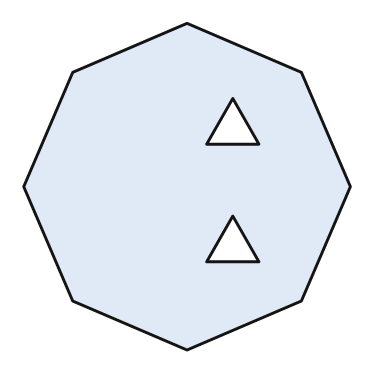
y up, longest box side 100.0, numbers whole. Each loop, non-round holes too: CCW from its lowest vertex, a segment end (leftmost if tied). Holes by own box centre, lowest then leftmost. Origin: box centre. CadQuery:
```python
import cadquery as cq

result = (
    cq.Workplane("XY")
    .moveTo(0.0, -50.0)
    .lineTo(35.0, -35.0)
    .lineTo(50.0, 0.0)
    .lineTo(35.0, 35.0)
    .lineTo(0.0, 50.0)
    .lineTo(-35.0, 35.0)
    .lineTo(-50.0, 0.0)
    .lineTo(-35.0, -35.0)
    .close()
    .moveTo(6.0, -23.0)
    .lineTo(22.0, -23.0)
    .lineTo(14.0, -9.0)
    .close()
    .moveTo(6.0, 13.0)
    .lineTo(22.0, 13.0)
    .lineTo(14.0, 27.0)
    .close()
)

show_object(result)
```